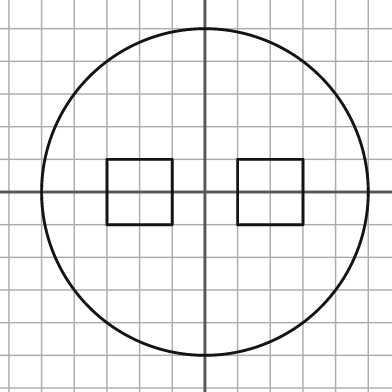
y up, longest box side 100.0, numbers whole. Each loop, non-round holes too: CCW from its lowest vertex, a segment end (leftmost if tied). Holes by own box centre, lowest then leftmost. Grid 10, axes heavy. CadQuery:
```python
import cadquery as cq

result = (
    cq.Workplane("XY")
    .moveTo(0.0, 0.0)
    .circle(50.0)
    .moveTo(-30.0, -10.0)
    .lineTo(-10.0, -10.0)
    .lineTo(-10.0, 10.0)
    .lineTo(-30.0, 10.0)
    .close()
    .moveTo(10.0, -10.0)
    .lineTo(30.0, -10.0)
    .lineTo(30.0, 10.0)
    .lineTo(10.0, 10.0)
    .close()
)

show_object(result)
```